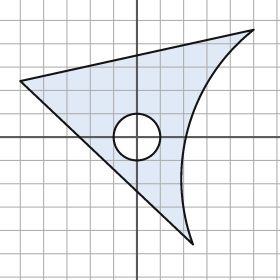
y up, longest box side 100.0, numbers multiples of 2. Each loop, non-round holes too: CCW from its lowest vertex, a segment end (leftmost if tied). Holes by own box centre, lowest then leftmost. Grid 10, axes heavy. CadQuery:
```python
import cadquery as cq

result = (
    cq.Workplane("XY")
    .moveTo(24.0, -46.0)
    .threePointArc((22.0, 4.0), (50.0, 46.0))
    .lineTo(-50.0, 24.0)
    .close()
    .moveTo(0.0, 0.0)
    .circle(10.0)
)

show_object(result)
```